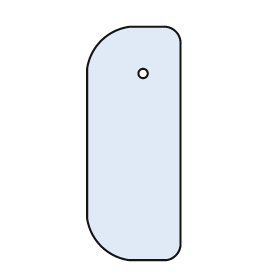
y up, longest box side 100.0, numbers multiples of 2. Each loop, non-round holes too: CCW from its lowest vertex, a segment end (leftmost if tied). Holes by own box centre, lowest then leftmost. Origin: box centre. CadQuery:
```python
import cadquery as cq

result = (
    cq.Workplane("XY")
    .moveTo(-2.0, -50.0)
    .lineTo(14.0, -50.0)
    .threePointArc((18.0, -48.0), (20.0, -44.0))
    .lineTo(20.0, 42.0)
    .threePointArc((18.0, 48.0), (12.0, 50.0))
    .lineTo(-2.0, 50.0)
    .threePointArc((-14.0, 44.0), (-20.0, 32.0))
    .lineTo(-20.0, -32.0)
    .threePointArc((-14.0, -44.0), (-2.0, -50.0))
    .close()
    .moveTo(4.0, 30.0)
    .circle(2.0)
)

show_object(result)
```